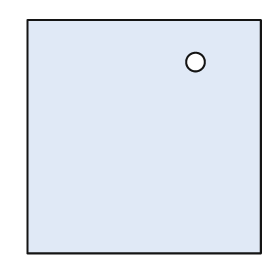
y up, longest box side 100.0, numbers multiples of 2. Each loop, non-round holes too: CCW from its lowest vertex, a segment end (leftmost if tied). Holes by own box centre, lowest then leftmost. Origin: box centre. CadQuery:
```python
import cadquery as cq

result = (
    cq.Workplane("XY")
    .moveTo(-50.0, -50.0)
    .lineTo(50.0, -50.0)
    .lineTo(50.0, 50.0)
    .lineTo(-50.0, 50.0)
    .close()
    .moveTo(22.0, 32.0)
    .circle(4.0)
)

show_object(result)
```